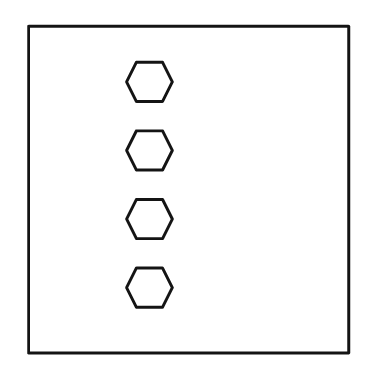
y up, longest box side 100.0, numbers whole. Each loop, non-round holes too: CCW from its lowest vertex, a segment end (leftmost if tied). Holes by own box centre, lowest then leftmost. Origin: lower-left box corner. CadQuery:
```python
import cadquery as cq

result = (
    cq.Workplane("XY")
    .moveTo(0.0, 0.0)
    .lineTo(98.0, 0.0)
    .lineTo(98.0, 100.0)
    .lineTo(0.0, 100.0)
    .close()
    .moveTo(33.0, 14.0)
    .lineTo(41.0, 14.0)
    .lineTo(44.0, 20.0)
    .lineTo(41.0, 26.0)
    .lineTo(33.0, 26.0)
    .lineTo(30.0, 20.0)
    .close()
    .moveTo(33.0, 35.0)
    .lineTo(41.0, 35.0)
    .lineTo(44.0, 41.0)
    .lineTo(41.0, 47.0)
    .lineTo(33.0, 47.0)
    .lineTo(30.0, 41.0)
    .close()
    .moveTo(33.0, 56.0)
    .lineTo(41.0, 56.0)
    .lineTo(44.0, 62.0)
    .lineTo(41.0, 68.0)
    .lineTo(33.0, 68.0)
    .lineTo(30.0, 62.0)
    .close()
    .moveTo(33.0, 77.0)
    .lineTo(41.0, 77.0)
    .lineTo(44.0, 83.0)
    .lineTo(41.0, 89.0)
    .lineTo(33.0, 89.0)
    .lineTo(30.0, 83.0)
    .close()
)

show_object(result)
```